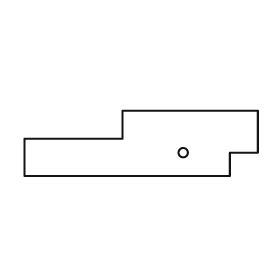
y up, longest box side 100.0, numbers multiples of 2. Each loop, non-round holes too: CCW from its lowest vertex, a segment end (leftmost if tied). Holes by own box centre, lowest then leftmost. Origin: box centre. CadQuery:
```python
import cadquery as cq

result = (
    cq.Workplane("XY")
    .moveTo(-50.0, -14.0)
    .lineTo(38.0, -14.0)
    .lineTo(38.0, -4.0)
    .lineTo(50.0, -4.0)
    .lineTo(50.0, 14.0)
    .lineTo(-8.0, 14.0)
    .lineTo(-8.0, 2.0)
    .lineTo(-50.0, 2.0)
    .close()
    .moveTo(18.0, -4.0)
    .circle(2.0)
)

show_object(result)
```